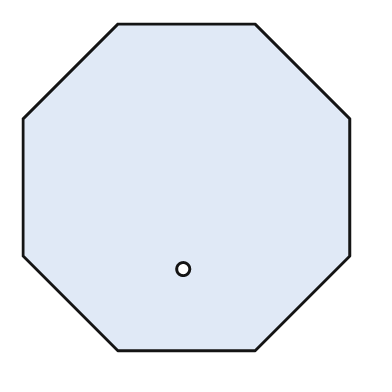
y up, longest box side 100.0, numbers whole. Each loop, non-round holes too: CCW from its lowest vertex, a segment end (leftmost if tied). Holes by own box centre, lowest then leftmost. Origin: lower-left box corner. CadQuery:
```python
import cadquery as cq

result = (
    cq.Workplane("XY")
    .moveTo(29.0, 0.0)
    .lineTo(71.0, 0.0)
    .lineTo(100.0, 29.0)
    .lineTo(100.0, 71.0)
    .lineTo(71.0, 100.0)
    .lineTo(29.0, 100.0)
    .lineTo(0.0, 71.0)
    .lineTo(0.0, 29.0)
    .close()
    .moveTo(49.0, 25.0)
    .circle(2.0)
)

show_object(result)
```